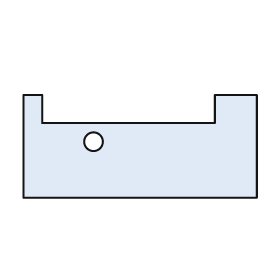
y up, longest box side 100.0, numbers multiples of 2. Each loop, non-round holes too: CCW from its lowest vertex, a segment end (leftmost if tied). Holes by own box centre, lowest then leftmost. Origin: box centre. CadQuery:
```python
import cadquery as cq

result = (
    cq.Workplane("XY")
    .moveTo(-50.0, -22.0)
    .lineTo(50.0, -22.0)
    .lineTo(50.0, 22.0)
    .lineTo(32.0, 22.0)
    .lineTo(32.0, 10.0)
    .lineTo(-42.0, 10.0)
    .lineTo(-42.0, 22.0)
    .lineTo(-50.0, 22.0)
    .close()
    .moveTo(-20.0, 2.0)
    .circle(4.0)
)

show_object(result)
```